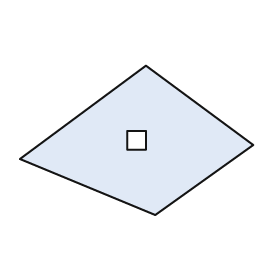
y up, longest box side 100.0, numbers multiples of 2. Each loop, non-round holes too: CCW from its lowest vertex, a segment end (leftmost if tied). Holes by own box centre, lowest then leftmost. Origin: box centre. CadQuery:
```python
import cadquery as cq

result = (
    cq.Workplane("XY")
    .moveTo(8.0, -32.0)
    .lineTo(50.0, -2.0)
    .lineTo(4.0, 32.0)
    .lineTo(-50.0, -8.0)
    .close()
    .moveTo(-4.0, -4.0)
    .lineTo(4.0, -4.0)
    .lineTo(4.0, 4.0)
    .lineTo(-4.0, 4.0)
    .close()
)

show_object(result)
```